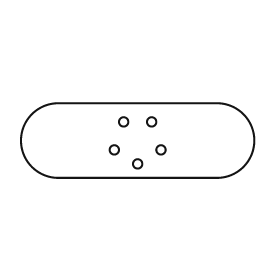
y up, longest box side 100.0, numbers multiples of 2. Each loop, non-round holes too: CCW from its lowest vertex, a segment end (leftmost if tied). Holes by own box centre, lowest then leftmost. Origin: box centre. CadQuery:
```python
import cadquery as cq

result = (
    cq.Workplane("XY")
    .moveTo(-34.0, -16.0)
    .lineTo(34.0, -16.0)
    .threePointArc((50.0, 0.0), (34.0, 16.0))
    .lineTo(-34.0, 16.0)
    .threePointArc((-50.0, 0.0), (-34.0, -16.0))
    .close()
    .moveTo(0.0, -10.0)
    .circle(2.0)
    .moveTo(-10.0, -4.0)
    .circle(2.0)
    .moveTo(10.0, -4.0)
    .circle(2.0)
    .moveTo(-6.0, 8.0)
    .circle(2.0)
    .moveTo(6.0, 8.0)
    .circle(2.0)
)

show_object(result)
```